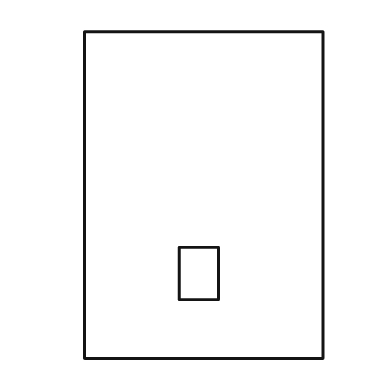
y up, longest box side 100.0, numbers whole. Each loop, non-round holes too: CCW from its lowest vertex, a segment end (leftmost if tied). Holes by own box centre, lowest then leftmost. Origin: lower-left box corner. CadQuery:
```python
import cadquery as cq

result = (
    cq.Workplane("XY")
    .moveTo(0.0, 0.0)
    .lineTo(73.0, 0.0)
    .lineTo(73.0, 100.0)
    .lineTo(0.0, 100.0)
    .close()
    .moveTo(29.0, 18.0)
    .lineTo(41.0, 18.0)
    .lineTo(41.0, 34.0)
    .lineTo(29.0, 34.0)
    .close()
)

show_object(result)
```